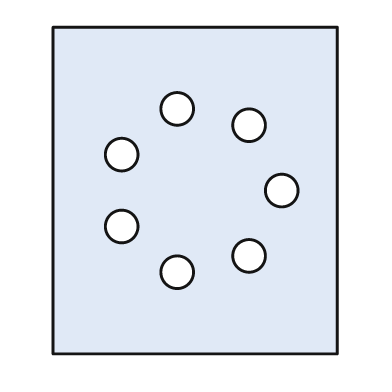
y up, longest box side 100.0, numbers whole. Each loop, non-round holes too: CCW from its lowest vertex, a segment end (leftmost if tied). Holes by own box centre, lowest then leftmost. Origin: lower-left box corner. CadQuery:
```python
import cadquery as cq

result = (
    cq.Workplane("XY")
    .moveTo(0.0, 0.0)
    .lineTo(87.0, 0.0)
    .lineTo(87.0, 100.0)
    .lineTo(0.0, 100.0)
    .close()
    .moveTo(38.0, 25.0)
    .circle(5.0)
    .moveTo(60.0, 30.0)
    .circle(5.0)
    .moveTo(21.0, 39.0)
    .circle(5.0)
    .moveTo(70.0, 50.0)
    .circle(5.0)
    .moveTo(21.0, 61.0)
    .circle(5.0)
    .moveTo(60.0, 70.0)
    .circle(5.0)
    .moveTo(38.0, 75.0)
    .circle(5.0)
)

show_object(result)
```